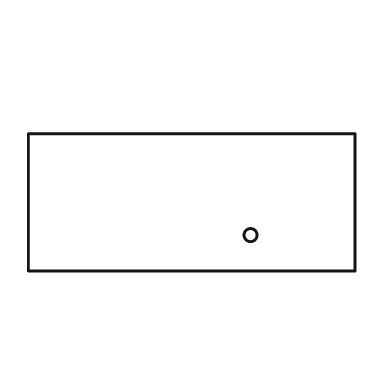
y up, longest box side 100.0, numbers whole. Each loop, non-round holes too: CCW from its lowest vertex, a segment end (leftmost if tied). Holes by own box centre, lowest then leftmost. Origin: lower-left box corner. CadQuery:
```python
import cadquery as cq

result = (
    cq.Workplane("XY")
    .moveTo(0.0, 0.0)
    .lineTo(100.0, 0.0)
    .lineTo(100.0, 42.0)
    .lineTo(0.0, 42.0)
    .close()
    .moveTo(68.0, 11.0)
    .circle(2.0)
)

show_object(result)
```